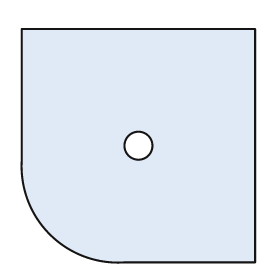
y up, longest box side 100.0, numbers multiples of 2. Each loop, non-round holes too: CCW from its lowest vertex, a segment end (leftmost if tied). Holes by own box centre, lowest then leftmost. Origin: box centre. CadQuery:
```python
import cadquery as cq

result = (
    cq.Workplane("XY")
    .moveTo(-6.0, -50.0)
    .lineTo(50.0, -50.0)
    .lineTo(50.0, 50.0)
    .lineTo(-50.0, 50.0)
    .lineTo(-50.0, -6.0)
    .threePointArc((-38.0, -38.0), (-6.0, -50.0))
    .close()
    .moveTo(0.0, 0.0)
    .circle(6.0)
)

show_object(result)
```